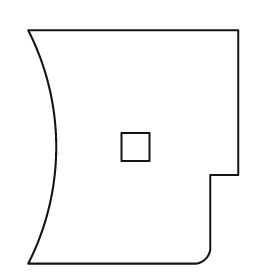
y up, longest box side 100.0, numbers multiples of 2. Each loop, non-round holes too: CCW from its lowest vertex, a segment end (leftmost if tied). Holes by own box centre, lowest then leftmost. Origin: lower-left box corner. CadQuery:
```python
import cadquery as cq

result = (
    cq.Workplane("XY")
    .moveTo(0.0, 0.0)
    .lineTo(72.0, 0.0)
    .threePointArc((76.0, 2.0), (78.0, 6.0))
    .lineTo(78.0, 38.0)
    .lineTo(90.0, 38.0)
    .lineTo(90.0, 100.0)
    .lineTo(0.0, 100.0)
    .threePointArc((12.0, 50.0), (0.0, 0.0))
    .close()
    .moveTo(40.0, 44.0)
    .lineTo(52.0, 44.0)
    .lineTo(52.0, 56.0)
    .lineTo(40.0, 56.0)
    .close()
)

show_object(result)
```